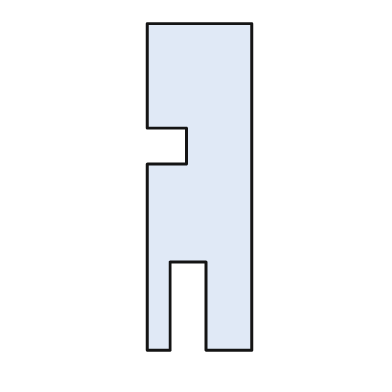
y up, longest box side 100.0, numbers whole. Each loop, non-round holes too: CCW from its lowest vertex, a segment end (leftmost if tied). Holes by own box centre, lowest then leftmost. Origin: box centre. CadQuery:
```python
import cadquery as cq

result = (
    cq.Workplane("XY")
    .moveTo(-16.0, -50.0)
    .lineTo(-9.0, -50.0)
    .lineTo(-9.0, -23.0)
    .lineTo(2.0, -23.0)
    .lineTo(2.0, -50.0)
    .lineTo(16.0, -50.0)
    .lineTo(16.0, 50.0)
    .lineTo(-16.0, 50.0)
    .lineTo(-16.0, 18.0)
    .lineTo(-4.0, 18.0)
    .lineTo(-4.0, 7.0)
    .lineTo(-16.0, 7.0)
    .close()
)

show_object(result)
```